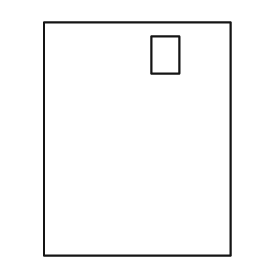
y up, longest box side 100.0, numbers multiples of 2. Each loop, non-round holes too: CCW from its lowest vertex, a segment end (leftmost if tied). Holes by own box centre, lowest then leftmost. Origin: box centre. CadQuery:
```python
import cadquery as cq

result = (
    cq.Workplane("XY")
    .moveTo(-40.0, -50.0)
    .lineTo(40.0, -50.0)
    .lineTo(40.0, 50.0)
    .lineTo(-40.0, 50.0)
    .close()
    .moveTo(6.0, 28.0)
    .lineTo(18.0, 28.0)
    .lineTo(18.0, 44.0)
    .lineTo(6.0, 44.0)
    .close()
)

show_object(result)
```